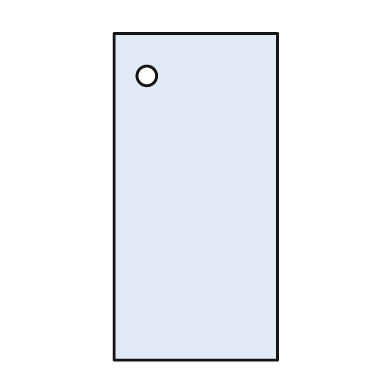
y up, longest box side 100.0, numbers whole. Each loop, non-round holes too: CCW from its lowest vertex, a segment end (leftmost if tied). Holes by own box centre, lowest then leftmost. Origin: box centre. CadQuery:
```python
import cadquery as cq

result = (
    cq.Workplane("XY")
    .moveTo(-25.0, -50.0)
    .lineTo(25.0, -50.0)
    .lineTo(25.0, 50.0)
    .lineTo(-25.0, 50.0)
    .close()
    .moveTo(-15.0, 37.0)
    .circle(3.0)
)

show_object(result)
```